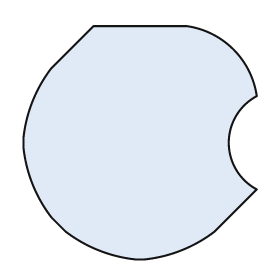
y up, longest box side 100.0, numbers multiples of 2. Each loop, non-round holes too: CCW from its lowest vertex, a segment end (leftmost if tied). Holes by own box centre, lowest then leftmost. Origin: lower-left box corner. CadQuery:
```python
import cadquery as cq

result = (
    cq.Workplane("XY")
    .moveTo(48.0, 0.0)
    .lineTo(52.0, 0.0)
    .threePointArc((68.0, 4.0), (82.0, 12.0))
    .lineTo(100.0, 30.0)
    .threePointArc((88.0, 50.0), (100.0, 70.0))
    .threePointArc((90.0, 90.0), (70.0, 100.0))
    .lineTo(30.0, 100.0)
    .lineTo(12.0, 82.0)
    .threePointArc((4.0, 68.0), (0.0, 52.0))
    .lineTo(0.0, 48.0)
    .threePointArc((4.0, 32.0), (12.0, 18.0))
    .lineTo(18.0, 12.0)
    .threePointArc((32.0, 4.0), (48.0, 0.0))
    .close()
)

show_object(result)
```